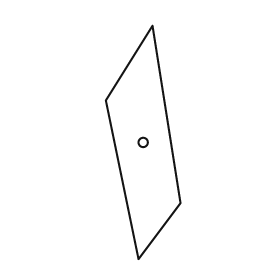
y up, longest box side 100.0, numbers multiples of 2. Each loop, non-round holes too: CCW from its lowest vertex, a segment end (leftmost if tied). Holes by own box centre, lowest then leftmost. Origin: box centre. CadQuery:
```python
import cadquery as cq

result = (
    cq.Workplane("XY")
    .moveTo(-2.0, -50.0)
    .lineTo(16.0, -26.0)
    .lineTo(4.0, 50.0)
    .lineTo(-16.0, 18.0)
    .close()
    .moveTo(0.0, 0.0)
    .circle(2.0)
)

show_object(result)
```